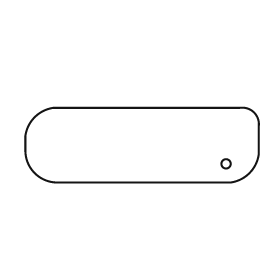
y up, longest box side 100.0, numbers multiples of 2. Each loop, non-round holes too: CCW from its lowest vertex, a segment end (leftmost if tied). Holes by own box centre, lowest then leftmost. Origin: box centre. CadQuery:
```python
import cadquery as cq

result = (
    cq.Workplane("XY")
    .moveTo(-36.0, -16.0)
    .lineTo(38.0, -16.0)
    .threePointArc((46.0, -12.0), (50.0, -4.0))
    .lineTo(50.0, 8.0)
    .threePointArc((48.0, 14.0), (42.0, 16.0))
    .lineTo(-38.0, 16.0)
    .threePointArc((-46.0, 12.0), (-50.0, 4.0))
    .lineTo(-50.0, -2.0)
    .threePointArc((-46.0, -12.0), (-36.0, -16.0))
    .close()
    .moveTo(36.0, -8.0)
    .circle(2.0)
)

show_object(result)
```